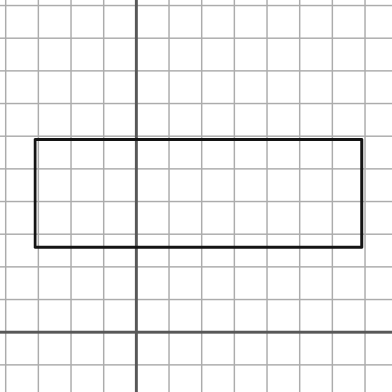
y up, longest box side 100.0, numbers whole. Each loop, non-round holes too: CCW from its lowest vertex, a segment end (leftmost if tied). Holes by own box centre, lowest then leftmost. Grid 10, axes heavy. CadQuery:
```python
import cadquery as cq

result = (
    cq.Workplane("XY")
    .moveTo(-31.0, 26.0)
    .lineTo(69.0, 26.0)
    .lineTo(69.0, 59.0)
    .lineTo(-31.0, 59.0)
    .close()
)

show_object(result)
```